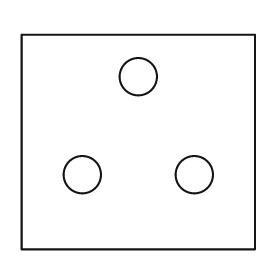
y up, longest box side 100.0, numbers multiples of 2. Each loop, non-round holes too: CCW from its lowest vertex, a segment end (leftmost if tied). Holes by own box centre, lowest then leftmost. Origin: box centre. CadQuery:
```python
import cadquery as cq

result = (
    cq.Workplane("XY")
    .moveTo(-50.0, -46.0)
    .lineTo(50.0, -46.0)
    .lineTo(50.0, 46.0)
    .lineTo(-50.0, 46.0)
    .close()
    .moveTo(-24.0, -14.0)
    .circle(8.0)
    .moveTo(24.0, -14.0)
    .circle(8.0)
    .moveTo(0.0, 28.0)
    .circle(8.0)
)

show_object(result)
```